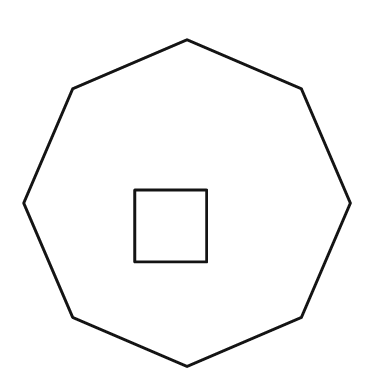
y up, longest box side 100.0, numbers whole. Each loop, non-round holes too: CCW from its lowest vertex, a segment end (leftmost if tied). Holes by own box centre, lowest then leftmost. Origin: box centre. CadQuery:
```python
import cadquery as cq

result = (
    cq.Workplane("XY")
    .moveTo(0.0, -50.0)
    .lineTo(35.0, -35.0)
    .lineTo(50.0, 0.0)
    .lineTo(35.0, 35.0)
    .lineTo(0.0, 50.0)
    .lineTo(-35.0, 35.0)
    .lineTo(-50.0, 0.0)
    .lineTo(-35.0, -35.0)
    .close()
    .moveTo(-16.0, -18.0)
    .lineTo(6.0, -18.0)
    .lineTo(6.0, 4.0)
    .lineTo(-16.0, 4.0)
    .close()
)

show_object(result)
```